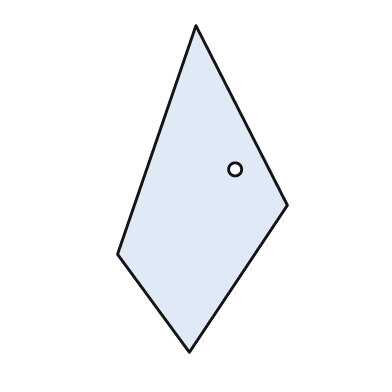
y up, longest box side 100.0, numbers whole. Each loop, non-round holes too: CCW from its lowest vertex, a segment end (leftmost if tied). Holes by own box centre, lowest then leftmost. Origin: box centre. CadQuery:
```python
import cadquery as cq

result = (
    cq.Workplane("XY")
    .moveTo(-4.0, -50.0)
    .lineTo(26.0, -5.0)
    .lineTo(-2.0, 50.0)
    .lineTo(-26.0, -20.0)
    .close()
    .moveTo(10.0, 6.0)
    .circle(2.0)
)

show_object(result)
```